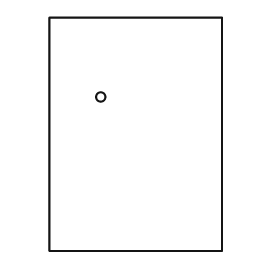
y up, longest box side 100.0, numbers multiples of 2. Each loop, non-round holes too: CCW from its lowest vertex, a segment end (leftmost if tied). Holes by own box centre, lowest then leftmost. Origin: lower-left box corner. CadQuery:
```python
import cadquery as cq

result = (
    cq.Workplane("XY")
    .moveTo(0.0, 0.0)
    .lineTo(74.0, 0.0)
    .lineTo(74.0, 100.0)
    .lineTo(0.0, 100.0)
    .close()
    .moveTo(22.0, 66.0)
    .circle(2.0)
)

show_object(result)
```